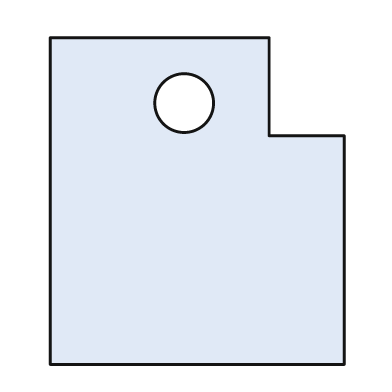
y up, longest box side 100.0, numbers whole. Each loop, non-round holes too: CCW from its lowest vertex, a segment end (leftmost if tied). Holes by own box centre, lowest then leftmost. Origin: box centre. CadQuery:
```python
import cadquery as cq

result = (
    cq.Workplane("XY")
    .moveTo(-45.0, -50.0)
    .lineTo(45.0, -50.0)
    .lineTo(45.0, 20.0)
    .lineTo(22.0, 20.0)
    .lineTo(22.0, 50.0)
    .lineTo(-45.0, 50.0)
    .close()
    .moveTo(-4.0, 30.0)
    .circle(9.0)
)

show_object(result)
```